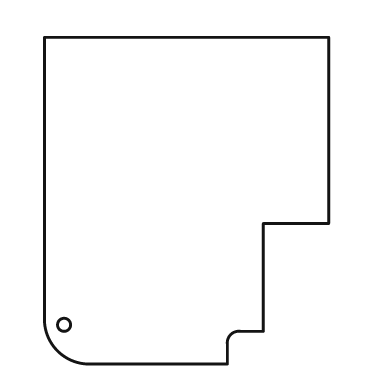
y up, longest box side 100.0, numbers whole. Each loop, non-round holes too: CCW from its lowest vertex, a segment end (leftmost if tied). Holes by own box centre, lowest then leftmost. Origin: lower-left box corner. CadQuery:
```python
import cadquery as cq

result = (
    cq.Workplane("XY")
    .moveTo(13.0, 0.0)
    .lineTo(56.0, 0.0)
    .lineTo(56.0, 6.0)
    .threePointArc((57.0, 9.0), (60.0, 10.0))
    .lineTo(67.0, 10.0)
    .lineTo(67.0, 43.0)
    .lineTo(87.0, 43.0)
    .lineTo(87.0, 100.0)
    .lineTo(0.0, 100.0)
    .lineTo(0.0, 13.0)
    .threePointArc((4.0, 4.0), (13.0, 0.0))
    .close()
    .moveTo(6.0, 12.0)
    .circle(2.0)
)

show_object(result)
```